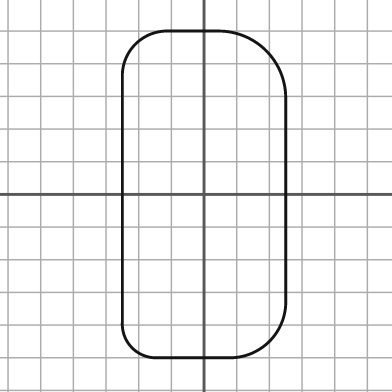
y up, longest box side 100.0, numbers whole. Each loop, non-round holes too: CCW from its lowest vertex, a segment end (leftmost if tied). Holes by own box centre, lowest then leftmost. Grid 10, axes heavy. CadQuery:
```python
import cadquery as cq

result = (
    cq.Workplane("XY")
    .moveTo(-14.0, -50.0)
    .lineTo(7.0, -50.0)
    .threePointArc((20.0, -45.0), (25.0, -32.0))
    .lineTo(25.0, 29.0)
    .threePointArc((19.0, 44.0), (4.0, 50.0))
    .lineTo(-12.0, 50.0)
    .threePointArc((-21.0, 46.0), (-25.0, 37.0))
    .lineTo(-25.0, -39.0)
    .threePointArc((-22.0, -47.0), (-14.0, -50.0))
    .close()
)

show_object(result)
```